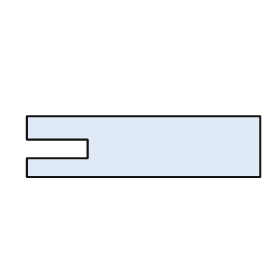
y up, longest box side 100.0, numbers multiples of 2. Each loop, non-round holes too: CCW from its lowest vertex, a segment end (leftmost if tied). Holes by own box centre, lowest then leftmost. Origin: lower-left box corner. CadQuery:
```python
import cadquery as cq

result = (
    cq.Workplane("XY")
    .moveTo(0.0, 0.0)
    .lineTo(100.0, 0.0)
    .lineTo(100.0, 26.0)
    .lineTo(0.0, 26.0)
    .lineTo(0.0, 16.0)
    .lineTo(26.0, 16.0)
    .lineTo(26.0, 8.0)
    .lineTo(0.0, 8.0)
    .close()
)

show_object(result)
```